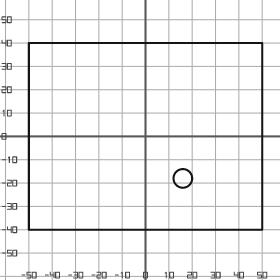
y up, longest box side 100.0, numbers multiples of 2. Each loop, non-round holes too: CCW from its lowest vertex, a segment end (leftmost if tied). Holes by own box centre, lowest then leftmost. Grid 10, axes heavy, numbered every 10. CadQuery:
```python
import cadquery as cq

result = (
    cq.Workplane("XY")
    .moveTo(-50.0, -40.0)
    .lineTo(50.0, -40.0)
    .lineTo(50.0, 40.0)
    .lineTo(-50.0, 40.0)
    .close()
    .moveTo(16.0, -18.0)
    .circle(4.0)
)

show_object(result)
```